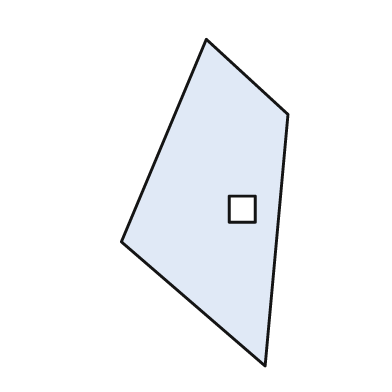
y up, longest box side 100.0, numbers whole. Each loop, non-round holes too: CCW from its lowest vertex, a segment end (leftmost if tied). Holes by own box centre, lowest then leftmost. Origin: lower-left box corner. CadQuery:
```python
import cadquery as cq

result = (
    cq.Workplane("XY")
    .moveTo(44.0, 0.0)
    .lineTo(51.0, 77.0)
    .lineTo(26.0, 100.0)
    .lineTo(0.0, 38.0)
    .close()
    .moveTo(33.0, 44.0)
    .lineTo(41.0, 44.0)
    .lineTo(41.0, 52.0)
    .lineTo(33.0, 52.0)
    .close()
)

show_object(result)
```